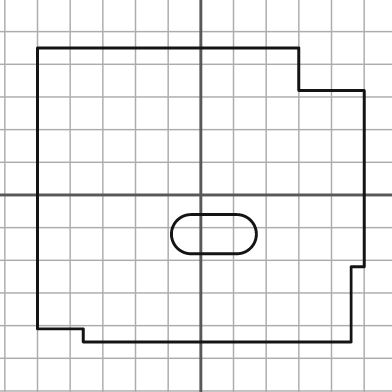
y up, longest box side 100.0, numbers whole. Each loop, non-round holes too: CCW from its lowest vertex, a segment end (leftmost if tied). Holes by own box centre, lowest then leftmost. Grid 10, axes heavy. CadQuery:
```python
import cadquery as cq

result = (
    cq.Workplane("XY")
    .moveTo(-36.0, -45.0)
    .lineTo(46.0, -45.0)
    .lineTo(46.0, -22.0)
    .lineTo(50.0, -22.0)
    .lineTo(50.0, 32.0)
    .lineTo(30.0, 32.0)
    .lineTo(30.0, 45.0)
    .lineTo(-50.0, 45.0)
    .lineTo(-50.0, -41.0)
    .lineTo(-36.0, -41.0)
    .close()
    .moveTo(-3.0, -18.0)
    .lineTo(11.0, -18.0)
    .threePointArc((17.0, -12.0), (11.0, -6.0))
    .lineTo(-3.0, -6.0)
    .threePointArc((-9.0, -12.0), (-3.0, -18.0))
    .close()
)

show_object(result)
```